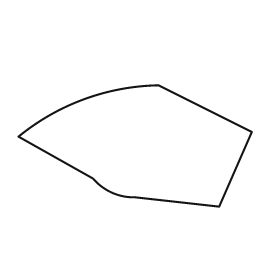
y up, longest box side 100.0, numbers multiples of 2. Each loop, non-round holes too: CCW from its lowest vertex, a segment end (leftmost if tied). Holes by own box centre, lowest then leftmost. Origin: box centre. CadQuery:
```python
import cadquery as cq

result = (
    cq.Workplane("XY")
    .moveTo(36.0, -26.0)
    .lineTo(50.0, 6.0)
    .lineTo(10.0, 26.0)
    .threePointArc((-22.0, 20.0), (-50.0, 4.0))
    .lineTo(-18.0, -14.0)
    .threePointArc((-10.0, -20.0), (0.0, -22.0))
    .close()
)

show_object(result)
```